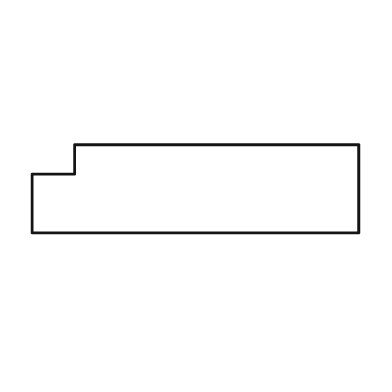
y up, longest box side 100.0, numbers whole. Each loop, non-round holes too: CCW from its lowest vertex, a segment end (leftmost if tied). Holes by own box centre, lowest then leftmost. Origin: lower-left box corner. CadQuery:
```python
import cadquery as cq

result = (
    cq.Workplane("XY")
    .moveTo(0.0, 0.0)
    .lineTo(100.0, 0.0)
    .lineTo(100.0, 27.0)
    .lineTo(13.0, 27.0)
    .lineTo(13.0, 18.0)
    .lineTo(0.0, 18.0)
    .close()
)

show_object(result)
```